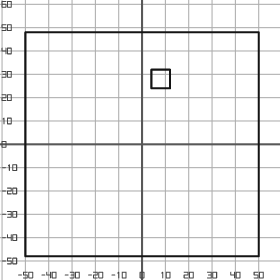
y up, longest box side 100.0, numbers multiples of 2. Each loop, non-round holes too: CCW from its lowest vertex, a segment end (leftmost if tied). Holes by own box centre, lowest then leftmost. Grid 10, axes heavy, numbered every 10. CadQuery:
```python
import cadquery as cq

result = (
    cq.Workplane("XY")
    .moveTo(-50.0, -48.0)
    .lineTo(50.0, -48.0)
    .lineTo(50.0, 48.0)
    .lineTo(-50.0, 48.0)
    .close()
    .moveTo(4.0, 24.0)
    .lineTo(12.0, 24.0)
    .lineTo(12.0, 32.0)
    .lineTo(4.0, 32.0)
    .close()
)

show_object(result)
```